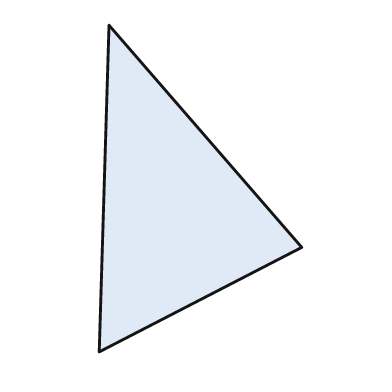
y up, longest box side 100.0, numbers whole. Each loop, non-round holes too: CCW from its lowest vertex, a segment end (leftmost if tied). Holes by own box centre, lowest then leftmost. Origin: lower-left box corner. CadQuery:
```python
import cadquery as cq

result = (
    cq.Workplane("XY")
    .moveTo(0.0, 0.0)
    .lineTo(62.0, 32.0)
    .lineTo(3.0, 100.0)
    .close()
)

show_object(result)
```